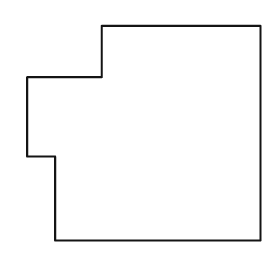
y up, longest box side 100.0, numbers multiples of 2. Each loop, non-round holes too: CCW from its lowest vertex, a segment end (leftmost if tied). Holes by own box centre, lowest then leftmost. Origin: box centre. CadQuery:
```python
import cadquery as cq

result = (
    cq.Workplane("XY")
    .moveTo(-38.0, -46.0)
    .lineTo(50.0, -46.0)
    .lineTo(50.0, 46.0)
    .lineTo(-18.0, 46.0)
    .lineTo(-18.0, 24.0)
    .lineTo(-50.0, 24.0)
    .lineTo(-50.0, -10.0)
    .lineTo(-38.0, -10.0)
    .close()
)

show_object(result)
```